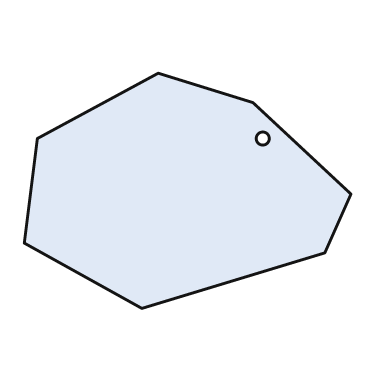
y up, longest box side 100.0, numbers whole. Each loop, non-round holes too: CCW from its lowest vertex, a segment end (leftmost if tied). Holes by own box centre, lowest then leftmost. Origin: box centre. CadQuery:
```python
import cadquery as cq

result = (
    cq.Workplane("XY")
    .moveTo(-14.0, -36.0)
    .lineTo(42.0, -19.0)
    .lineTo(50.0, -1.0)
    .lineTo(20.0, 27.0)
    .lineTo(-9.0, 36.0)
    .lineTo(-46.0, 16.0)
    .lineTo(-50.0, -16.0)
    .close()
    .moveTo(23.0, 16.0)
    .circle(2.0)
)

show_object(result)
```